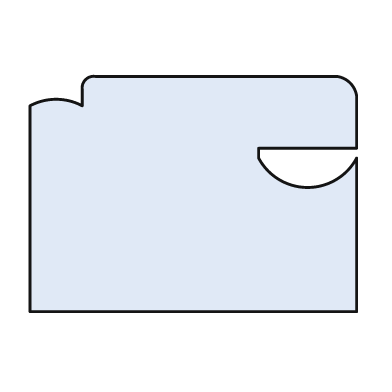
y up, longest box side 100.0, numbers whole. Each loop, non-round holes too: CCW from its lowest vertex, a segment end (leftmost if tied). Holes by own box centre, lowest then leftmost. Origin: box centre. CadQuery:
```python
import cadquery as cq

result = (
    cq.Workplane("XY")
    .moveTo(-50.0, -36.0)
    .lineTo(50.0, -36.0)
    .lineTo(50.0, 11.0)
    .threePointArc((35.0, 2.0), (20.0, 11.0))
    .lineTo(20.0, 14.0)
    .lineTo(50.0, 14.0)
    .lineTo(50.0, 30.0)
    .threePointArc((48.0, 34.0), (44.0, 36.0))
    .lineTo(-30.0, 36.0)
    .threePointArc((-33.0, 35.0), (-34.0, 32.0))
    .lineTo(-34.0, 27.0)
    .threePointArc((-42.0, 29.0), (-50.0, 27.0))
    .close()
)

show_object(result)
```